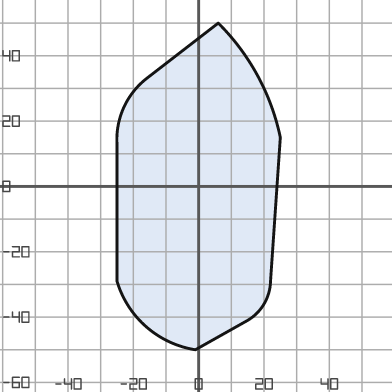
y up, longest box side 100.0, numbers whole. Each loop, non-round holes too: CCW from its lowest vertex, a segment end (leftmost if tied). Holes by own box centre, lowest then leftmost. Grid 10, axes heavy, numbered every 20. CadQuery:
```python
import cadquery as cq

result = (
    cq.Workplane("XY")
    .moveTo(-1.0, -50.0)
    .lineTo(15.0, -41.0)
    .threePointArc((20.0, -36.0), (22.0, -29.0))
    .lineTo(25.0, 15.0)
    .threePointArc((18.0, 34.0), (6.0, 50.0))
    .lineTo(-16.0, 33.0)
    .threePointArc((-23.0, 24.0), (-25.0, 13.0))
    .lineTo(-25.0, -29.0)
    .threePointArc((-16.0, -43.0), (-1.0, -50.0))
    .close()
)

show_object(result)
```